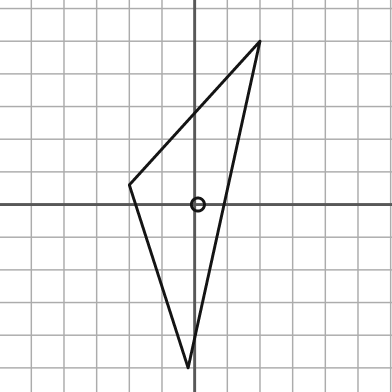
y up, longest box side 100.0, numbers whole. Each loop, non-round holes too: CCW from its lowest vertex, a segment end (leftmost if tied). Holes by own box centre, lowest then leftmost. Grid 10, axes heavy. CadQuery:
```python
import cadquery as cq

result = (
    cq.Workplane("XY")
    .moveTo(-2.0, -50.0)
    .lineTo(20.0, 50.0)
    .lineTo(-20.0, 6.0)
    .close()
    .moveTo(1.0, 0.0)
    .circle(2.0)
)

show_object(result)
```